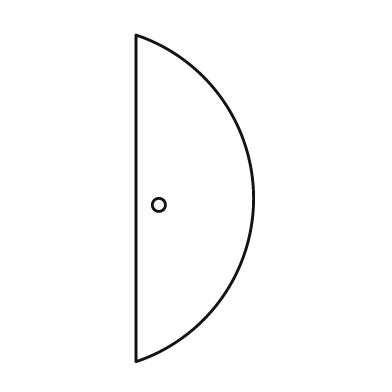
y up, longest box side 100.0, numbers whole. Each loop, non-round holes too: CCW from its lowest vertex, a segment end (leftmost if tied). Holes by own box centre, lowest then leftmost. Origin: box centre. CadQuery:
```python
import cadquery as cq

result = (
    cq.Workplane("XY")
    .moveTo(-18.0, -50.0)
    .threePointArc((18.0, 0.0), (-18.0, 50.0))
    .close()
    .moveTo(-11.0, -2.0)
    .circle(2.0)
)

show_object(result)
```